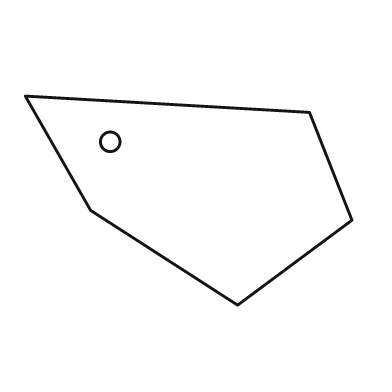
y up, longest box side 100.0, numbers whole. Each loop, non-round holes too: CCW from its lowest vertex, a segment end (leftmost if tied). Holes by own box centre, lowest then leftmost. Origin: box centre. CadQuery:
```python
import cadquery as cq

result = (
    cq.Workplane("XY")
    .moveTo(15.0, -32.0)
    .lineTo(50.0, -6.0)
    .lineTo(37.0, 27.0)
    .lineTo(-50.0, 32.0)
    .lineTo(-30.0, -3.0)
    .close()
    .moveTo(-24.0, 18.0)
    .circle(3.0)
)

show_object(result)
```